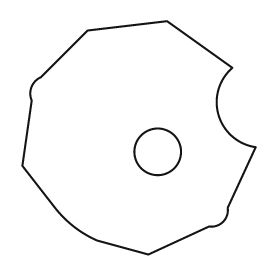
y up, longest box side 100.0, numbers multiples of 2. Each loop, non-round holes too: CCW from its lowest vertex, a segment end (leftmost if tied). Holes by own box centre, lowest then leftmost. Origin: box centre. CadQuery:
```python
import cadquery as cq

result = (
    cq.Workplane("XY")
    .moveTo(4.0, -50.0)
    .lineTo(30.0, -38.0)
    .threePointArc((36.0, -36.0), (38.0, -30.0))
    .lineTo(50.0, -4.0)
    .threePointArc((34.0, 10.0), (40.0, 30.0))
    .lineTo(12.0, 50.0)
    .lineTo(-22.0, 46.0)
    .lineTo(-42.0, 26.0)
    .threePointArc((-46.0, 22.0), (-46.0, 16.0))
    .lineTo(-50.0, -12.0)
    .lineTo(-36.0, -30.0)
    .threePointArc((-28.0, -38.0), (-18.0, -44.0))
    .close()
    .moveTo(8.0, -6.0)
    .circle(10.0)
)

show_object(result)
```